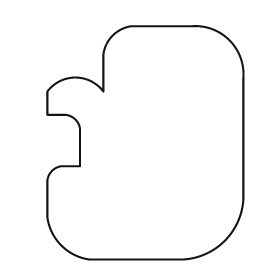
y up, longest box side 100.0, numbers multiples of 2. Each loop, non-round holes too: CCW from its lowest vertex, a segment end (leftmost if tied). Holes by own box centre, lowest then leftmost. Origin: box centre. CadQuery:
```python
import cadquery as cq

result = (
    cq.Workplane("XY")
    .moveTo(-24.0, -50.0)
    .lineTo(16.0, -50.0)
    .threePointArc((34.0, -42.0), (42.0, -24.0))
    .lineTo(42.0, 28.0)
    .threePointArc((36.0, 44.0), (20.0, 50.0))
    .lineTo(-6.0, 50.0)
    .threePointArc((-14.0, 46.0), (-18.0, 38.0))
    .lineTo(-18.0, 22.0)
    .threePointArc((-30.0, 28.0), (-42.0, 22.0))
    .lineTo(-42.0, 12.0)
    .lineTo(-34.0, 12.0)
    .threePointArc((-30.0, 10.0), (-28.0, 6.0))
    .lineTo(-28.0, -10.0)
    .lineTo(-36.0, -10.0)
    .threePointArc((-40.0, -12.0), (-42.0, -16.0))
    .lineTo(-42.0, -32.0)
    .threePointArc((-36.0, -44.0), (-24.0, -50.0))
    .close()
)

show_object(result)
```